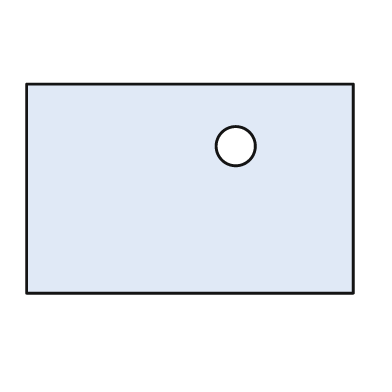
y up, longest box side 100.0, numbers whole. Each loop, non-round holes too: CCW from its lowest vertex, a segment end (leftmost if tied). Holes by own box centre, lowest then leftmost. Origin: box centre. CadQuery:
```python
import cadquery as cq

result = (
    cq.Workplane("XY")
    .moveTo(-50.0, -32.0)
    .lineTo(50.0, -32.0)
    .lineTo(50.0, 32.0)
    .lineTo(-50.0, 32.0)
    .close()
    .moveTo(14.0, 13.0)
    .circle(6.0)
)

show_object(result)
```